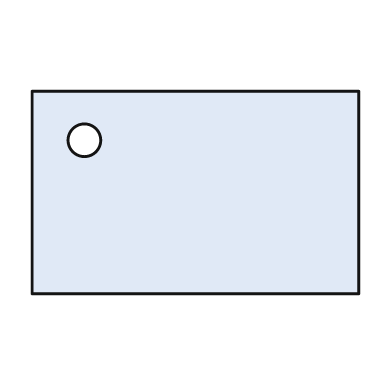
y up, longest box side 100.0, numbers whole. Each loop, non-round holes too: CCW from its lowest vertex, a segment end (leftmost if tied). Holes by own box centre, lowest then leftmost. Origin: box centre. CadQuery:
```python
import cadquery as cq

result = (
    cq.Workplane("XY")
    .moveTo(-50.0, -31.0)
    .lineTo(50.0, -31.0)
    .lineTo(50.0, 31.0)
    .lineTo(-50.0, 31.0)
    .close()
    .moveTo(-34.0, 16.0)
    .circle(5.0)
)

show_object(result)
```